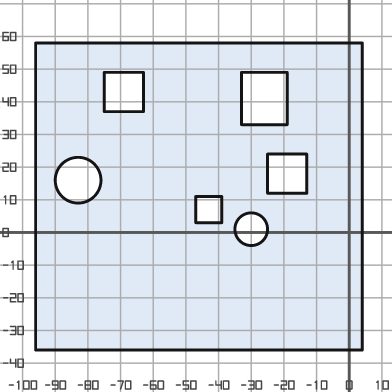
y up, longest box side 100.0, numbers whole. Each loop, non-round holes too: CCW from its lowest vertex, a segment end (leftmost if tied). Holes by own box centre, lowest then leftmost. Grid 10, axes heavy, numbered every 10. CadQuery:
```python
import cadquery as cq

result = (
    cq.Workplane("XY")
    .moveTo(-96.0, -36.0)
    .lineTo(4.0, -36.0)
    .lineTo(4.0, 58.0)
    .lineTo(-96.0, 58.0)
    .close()
    .moveTo(-30.0, 1.0)
    .circle(5.0)
    .moveTo(-47.0, 3.0)
    .lineTo(-39.0, 3.0)
    .lineTo(-39.0, 11.0)
    .lineTo(-47.0, 11.0)
    .close()
    .moveTo(-83.0, 16.0)
    .circle(7.0)
    .moveTo(-25.0, 12.0)
    .lineTo(-13.0, 12.0)
    .lineTo(-13.0, 24.0)
    .lineTo(-25.0, 24.0)
    .close()
    .moveTo(-33.0, 33.0)
    .lineTo(-19.0, 33.0)
    .lineTo(-19.0, 49.0)
    .lineTo(-33.0, 49.0)
    .close()
    .moveTo(-75.0, 37.0)
    .lineTo(-63.0, 37.0)
    .lineTo(-63.0, 49.0)
    .lineTo(-75.0, 49.0)
    .close()
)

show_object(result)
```